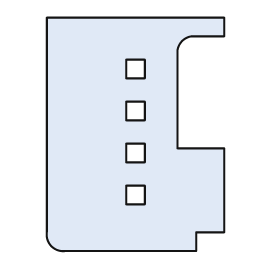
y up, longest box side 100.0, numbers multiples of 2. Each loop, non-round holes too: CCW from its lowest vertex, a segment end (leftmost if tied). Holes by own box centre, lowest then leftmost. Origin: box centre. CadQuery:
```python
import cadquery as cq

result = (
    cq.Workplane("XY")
    .moveTo(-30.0, -50.0)
    .lineTo(26.0, -50.0)
    .lineTo(26.0, -42.0)
    .lineTo(38.0, -42.0)
    .lineTo(38.0, -6.0)
    .lineTo(18.0, -6.0)
    .lineTo(18.0, 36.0)
    .threePointArc((20.0, 40.0), (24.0, 42.0))
    .lineTo(38.0, 42.0)
    .lineTo(38.0, 50.0)
    .lineTo(-38.0, 50.0)
    .lineTo(-38.0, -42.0)
    .threePointArc((-36.0, -48.0), (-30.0, -50.0))
    .close()
    .moveTo(-4.0, -30.0)
    .lineTo(4.0, -30.0)
    .lineTo(4.0, -22.0)
    .lineTo(-4.0, -22.0)
    .close()
    .moveTo(-4.0, -12.0)
    .lineTo(4.0, -12.0)
    .lineTo(4.0, -4.0)
    .lineTo(-4.0, -4.0)
    .close()
    .moveTo(-4.0, 6.0)
    .lineTo(4.0, 6.0)
    .lineTo(4.0, 14.0)
    .lineTo(-4.0, 14.0)
    .close()
    .moveTo(-4.0, 24.0)
    .lineTo(4.0, 24.0)
    .lineTo(4.0, 32.0)
    .lineTo(-4.0, 32.0)
    .close()
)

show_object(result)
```